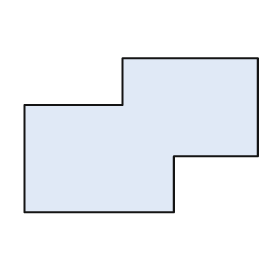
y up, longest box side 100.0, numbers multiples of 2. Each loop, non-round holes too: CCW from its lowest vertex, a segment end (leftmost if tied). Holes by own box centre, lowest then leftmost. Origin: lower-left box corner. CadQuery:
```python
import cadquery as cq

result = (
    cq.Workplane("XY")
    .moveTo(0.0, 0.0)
    .lineTo(64.0, 0.0)
    .lineTo(64.0, 24.0)
    .lineTo(100.0, 24.0)
    .lineTo(100.0, 66.0)
    .lineTo(42.0, 66.0)
    .lineTo(42.0, 46.0)
    .lineTo(0.0, 46.0)
    .close()
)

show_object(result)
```